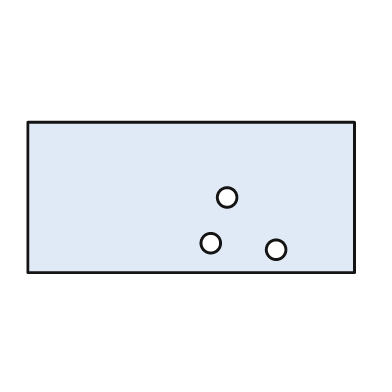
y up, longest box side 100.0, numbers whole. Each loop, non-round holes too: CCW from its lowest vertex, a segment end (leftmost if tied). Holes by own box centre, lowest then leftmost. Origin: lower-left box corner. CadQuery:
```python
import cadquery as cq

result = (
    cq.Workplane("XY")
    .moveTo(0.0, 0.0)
    .lineTo(100.0, 0.0)
    .lineTo(100.0, 46.0)
    .lineTo(0.0, 46.0)
    .close()
    .moveTo(76.0, 7.0)
    .circle(3.0)
    .moveTo(56.0, 9.0)
    .circle(3.0)
    .moveTo(61.0, 23.0)
    .circle(3.0)
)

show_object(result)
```